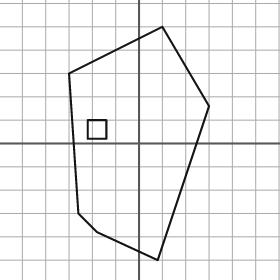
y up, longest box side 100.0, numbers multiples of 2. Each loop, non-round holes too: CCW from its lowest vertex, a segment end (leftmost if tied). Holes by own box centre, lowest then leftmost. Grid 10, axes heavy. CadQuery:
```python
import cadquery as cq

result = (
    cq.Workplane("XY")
    .moveTo(8.0, -50.0)
    .lineTo(30.0, 16.0)
    .lineTo(10.0, 50.0)
    .lineTo(-30.0, 30.0)
    .lineTo(-26.0, -30.0)
    .lineTo(-18.0, -38.0)
    .close()
    .moveTo(-22.0, 2.0)
    .lineTo(-14.0, 2.0)
    .lineTo(-14.0, 10.0)
    .lineTo(-22.0, 10.0)
    .close()
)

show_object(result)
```